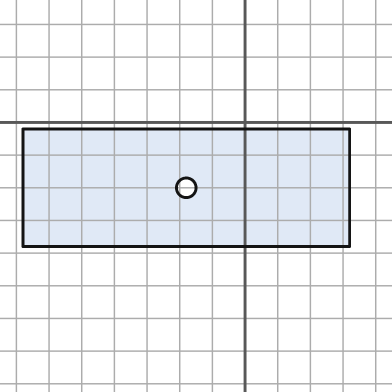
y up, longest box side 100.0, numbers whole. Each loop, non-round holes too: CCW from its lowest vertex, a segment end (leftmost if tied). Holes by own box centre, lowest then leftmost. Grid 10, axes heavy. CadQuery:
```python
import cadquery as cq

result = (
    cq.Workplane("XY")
    .moveTo(-68.0, -38.0)
    .lineTo(32.0, -38.0)
    .lineTo(32.0, -2.0)
    .lineTo(-68.0, -2.0)
    .close()
    .moveTo(-18.0, -20.0)
    .circle(3.0)
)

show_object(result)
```